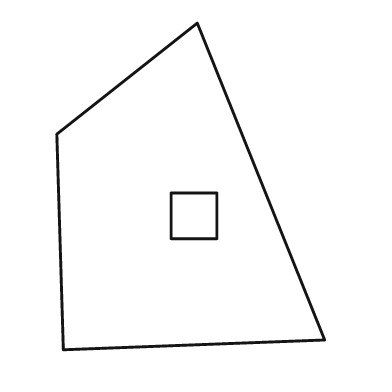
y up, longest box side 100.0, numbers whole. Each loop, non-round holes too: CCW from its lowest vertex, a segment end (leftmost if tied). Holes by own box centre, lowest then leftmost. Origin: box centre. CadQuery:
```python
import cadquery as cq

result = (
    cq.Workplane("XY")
    .moveTo(-39.0, -50.0)
    .lineTo(41.0, -47.0)
    .lineTo(2.0, 50.0)
    .lineTo(-41.0, 16.0)
    .close()
    .moveTo(-6.0, -16.0)
    .lineTo(8.0, -16.0)
    .lineTo(8.0, -2.0)
    .lineTo(-6.0, -2.0)
    .close()
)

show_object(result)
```